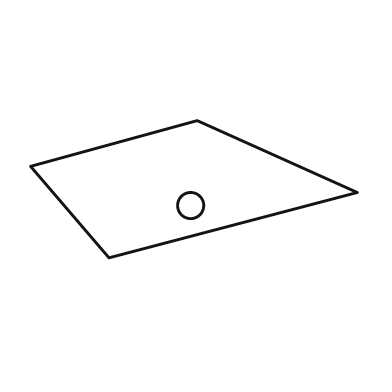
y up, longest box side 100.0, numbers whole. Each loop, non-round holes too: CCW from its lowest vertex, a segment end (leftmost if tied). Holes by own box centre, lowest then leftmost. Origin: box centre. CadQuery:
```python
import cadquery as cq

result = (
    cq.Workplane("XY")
    .moveTo(-26.0, -21.0)
    .lineTo(50.0, -1.0)
    .lineTo(1.0, 21.0)
    .lineTo(-50.0, 7.0)
    .close()
    .moveTo(-1.0, -5.0)
    .circle(4.0)
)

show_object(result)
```